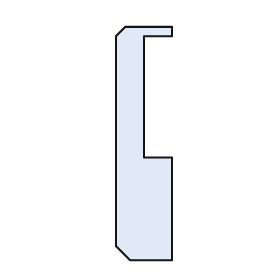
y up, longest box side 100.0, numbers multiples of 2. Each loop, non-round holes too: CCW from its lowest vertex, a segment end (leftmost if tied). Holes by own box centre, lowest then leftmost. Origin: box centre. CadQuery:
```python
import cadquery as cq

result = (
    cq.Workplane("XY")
    .moveTo(-6.0, -50.0)
    .lineTo(12.0, -50.0)
    .lineTo(12.0, -6.0)
    .lineTo(0.0, -6.0)
    .lineTo(0.0, 46.0)
    .lineTo(12.0, 46.0)
    .lineTo(12.0, 50.0)
    .lineTo(-8.0, 50.0)
    .lineTo(-12.0, 46.0)
    .lineTo(-12.0, -44.0)
    .close()
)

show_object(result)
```